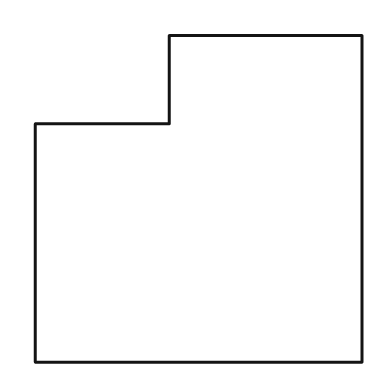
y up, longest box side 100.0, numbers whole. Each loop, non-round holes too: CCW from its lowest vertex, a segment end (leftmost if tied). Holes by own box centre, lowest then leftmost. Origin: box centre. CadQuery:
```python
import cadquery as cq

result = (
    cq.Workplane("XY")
    .moveTo(-50.0, -50.0)
    .lineTo(50.0, -50.0)
    .lineTo(50.0, 50.0)
    .lineTo(-9.0, 50.0)
    .lineTo(-9.0, 23.0)
    .lineTo(-50.0, 23.0)
    .close()
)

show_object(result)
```